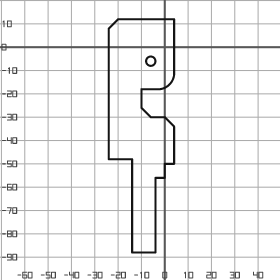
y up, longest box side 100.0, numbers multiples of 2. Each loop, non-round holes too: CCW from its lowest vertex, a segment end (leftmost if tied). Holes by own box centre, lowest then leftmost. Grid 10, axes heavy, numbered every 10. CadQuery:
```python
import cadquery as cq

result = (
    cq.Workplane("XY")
    .moveTo(-14.0, -88.0)
    .lineTo(-4.0, -88.0)
    .lineTo(-4.0, -56.0)
    .lineTo(0.0, -56.0)
    .lineTo(0.0, -50.0)
    .lineTo(4.0, -50.0)
    .lineTo(4.0, -34.0)
    .lineTo(0.0, -30.0)
    .lineTo(-6.0, -30.0)
    .lineTo(-10.0, -26.0)
    .lineTo(-10.0, -18.0)
    .lineTo(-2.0, -18.0)
    .threePointArc((2.0, -16.0), (4.0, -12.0))
    .lineTo(4.0, 12.0)
    .lineTo(-20.0, 12.0)
    .lineTo(-24.0, 8.0)
    .lineTo(-24.0, -48.0)
    .lineTo(-14.0, -48.0)
    .close()
    .moveTo(-6.0, -6.0)
    .circle(2.0)
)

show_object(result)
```